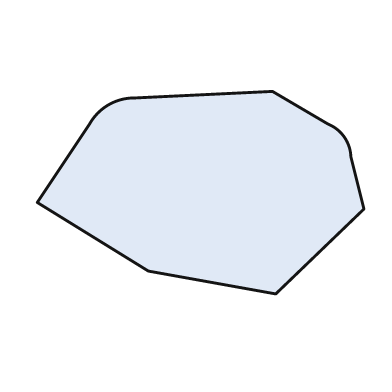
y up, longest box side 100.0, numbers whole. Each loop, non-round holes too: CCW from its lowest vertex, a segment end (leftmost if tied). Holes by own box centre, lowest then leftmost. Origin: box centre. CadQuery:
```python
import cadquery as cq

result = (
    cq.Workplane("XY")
    .moveTo(23.0, -31.0)
    .lineTo(50.0, -5.0)
    .lineTo(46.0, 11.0)
    .threePointArc((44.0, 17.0), (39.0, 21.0))
    .lineTo(22.0, 31.0)
    .lineTo(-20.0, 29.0)
    .threePointArc((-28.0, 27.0), (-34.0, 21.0))
    .lineTo(-50.0, -3.0)
    .lineTo(-16.0, -24.0)
    .close()
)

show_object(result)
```